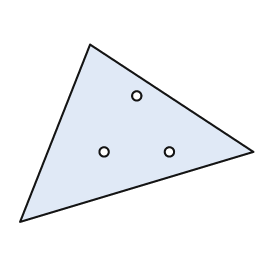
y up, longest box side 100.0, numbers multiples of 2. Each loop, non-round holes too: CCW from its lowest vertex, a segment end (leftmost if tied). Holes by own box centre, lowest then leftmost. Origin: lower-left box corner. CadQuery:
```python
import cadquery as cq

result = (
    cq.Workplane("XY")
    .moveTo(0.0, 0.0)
    .lineTo(100.0, 30.0)
    .lineTo(30.0, 76.0)
    .close()
    .moveTo(36.0, 30.0)
    .circle(2.0)
    .moveTo(64.0, 30.0)
    .circle(2.0)
    .moveTo(50.0, 54.0)
    .circle(2.0)
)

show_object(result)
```